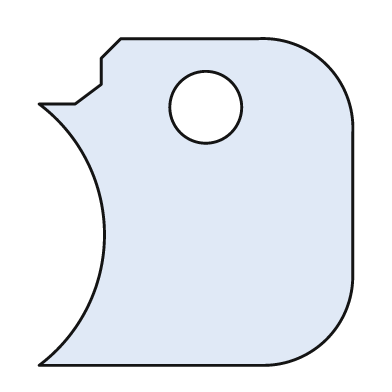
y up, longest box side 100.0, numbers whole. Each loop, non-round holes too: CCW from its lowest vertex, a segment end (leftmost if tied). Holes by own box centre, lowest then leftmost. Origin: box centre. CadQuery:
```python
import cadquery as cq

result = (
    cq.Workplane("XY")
    .moveTo(-48.0, -50.0)
    .lineTo(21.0, -50.0)
    .threePointArc((40.0, -42.0), (48.0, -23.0))
    .lineTo(48.0, 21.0)
    .threePointArc((40.0, 42.0), (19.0, 50.0))
    .lineTo(-23.0, 50.0)
    .lineTo(-29.0, 44.0)
    .lineTo(-29.0, 36.0)
    .lineTo(-37.0, 30.0)
    .lineTo(-48.0, 30.0)
    .threePointArc((-28.0, -10.0), (-48.0, -50.0))
    .close()
    .moveTo(3.0, 29.0)
    .circle(11.0)
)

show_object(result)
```